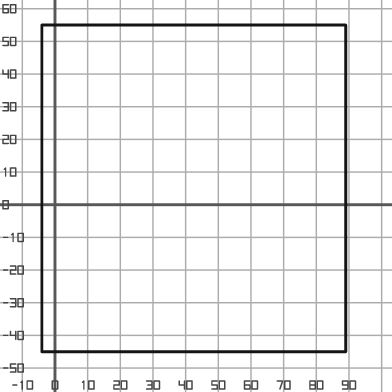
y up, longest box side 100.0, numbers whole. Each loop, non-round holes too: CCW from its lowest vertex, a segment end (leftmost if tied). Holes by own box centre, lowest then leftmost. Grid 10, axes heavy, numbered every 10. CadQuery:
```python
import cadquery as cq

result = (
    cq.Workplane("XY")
    .moveTo(-4.0, -45.0)
    .lineTo(89.0, -45.0)
    .lineTo(89.0, 55.0)
    .lineTo(-4.0, 55.0)
    .close()
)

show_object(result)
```